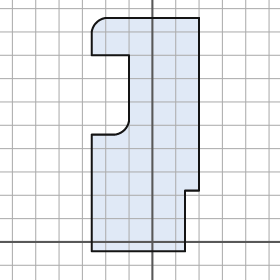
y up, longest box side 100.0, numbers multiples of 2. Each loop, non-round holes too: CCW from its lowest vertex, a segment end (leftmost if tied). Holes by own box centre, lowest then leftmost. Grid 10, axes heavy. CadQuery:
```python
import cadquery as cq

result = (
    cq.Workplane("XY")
    .moveTo(-26.0, -4.0)
    .lineTo(14.0, -4.0)
    .lineTo(14.0, 22.0)
    .lineTo(20.0, 22.0)
    .lineTo(20.0, 96.0)
    .lineTo(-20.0, 96.0)
    .threePointArc((-24.0, 94.0), (-26.0, 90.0))
    .lineTo(-26.0, 80.0)
    .lineTo(-10.0, 80.0)
    .lineTo(-10.0, 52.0)
    .threePointArc((-12.0, 48.0), (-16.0, 46.0))
    .lineTo(-26.0, 46.0)
    .close()
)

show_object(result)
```